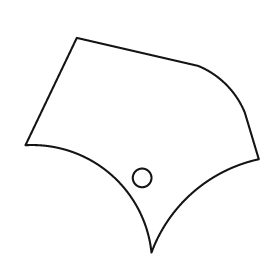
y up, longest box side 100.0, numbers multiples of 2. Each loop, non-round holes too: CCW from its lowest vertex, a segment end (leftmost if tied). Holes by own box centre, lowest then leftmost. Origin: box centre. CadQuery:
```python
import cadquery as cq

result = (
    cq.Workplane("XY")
    .moveTo(4.0, -46.0)
    .threePointArc((22.0, -20.0), (50.0, -6.0))
    .lineTo(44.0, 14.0)
    .threePointArc((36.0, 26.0), (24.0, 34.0))
    .lineTo(-28.0, 46.0)
    .lineTo(-50.0, 0.0)
    .threePointArc((-14.0, -12.0), (4.0, -46.0))
    .close()
    .moveTo(0.0, -14.0)
    .circle(4.0)
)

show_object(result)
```